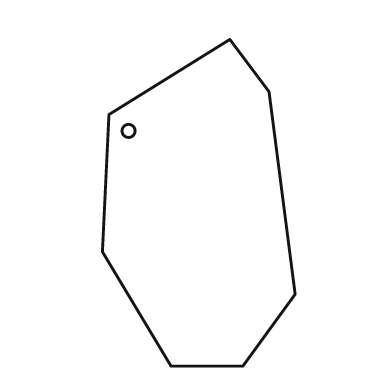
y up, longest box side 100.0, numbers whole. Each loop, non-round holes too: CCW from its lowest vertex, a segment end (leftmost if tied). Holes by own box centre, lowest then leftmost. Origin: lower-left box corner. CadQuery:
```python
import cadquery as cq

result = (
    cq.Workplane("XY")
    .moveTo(21.0, 0.0)
    .lineTo(43.0, 0.0)
    .lineTo(59.0, 22.0)
    .lineTo(51.0, 84.0)
    .lineTo(39.0, 100.0)
    .lineTo(2.0, 77.0)
    .lineTo(0.0, 35.0)
    .close()
    .moveTo(8.0, 72.0)
    .circle(2.0)
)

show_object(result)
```